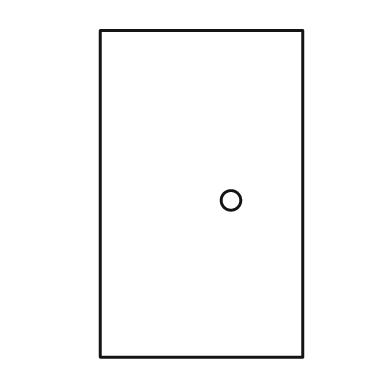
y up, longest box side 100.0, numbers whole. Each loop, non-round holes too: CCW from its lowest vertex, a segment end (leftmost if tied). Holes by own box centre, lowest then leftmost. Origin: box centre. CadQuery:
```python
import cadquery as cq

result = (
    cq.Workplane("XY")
    .moveTo(-31.0, -50.0)
    .lineTo(31.0, -50.0)
    .lineTo(31.0, 50.0)
    .lineTo(-31.0, 50.0)
    .close()
    .moveTo(9.0, -2.0)
    .circle(3.0)
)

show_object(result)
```